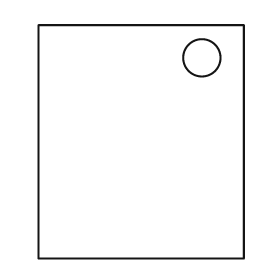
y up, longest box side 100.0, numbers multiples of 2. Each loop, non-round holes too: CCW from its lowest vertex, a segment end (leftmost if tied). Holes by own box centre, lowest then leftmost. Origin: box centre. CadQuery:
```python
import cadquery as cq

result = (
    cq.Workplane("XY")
    .moveTo(-44.0, -50.0)
    .lineTo(44.0, -50.0)
    .lineTo(44.0, 50.0)
    .lineTo(-44.0, 50.0)
    .close()
    .moveTo(26.0, 36.0)
    .circle(8.0)
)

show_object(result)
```